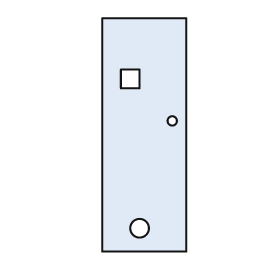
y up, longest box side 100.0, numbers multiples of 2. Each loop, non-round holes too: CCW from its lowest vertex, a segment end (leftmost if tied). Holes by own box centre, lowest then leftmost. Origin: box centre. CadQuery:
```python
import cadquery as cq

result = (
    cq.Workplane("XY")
    .moveTo(-18.0, -50.0)
    .lineTo(18.0, -50.0)
    .lineTo(18.0, 50.0)
    .lineTo(-18.0, 50.0)
    .close()
    .moveTo(-2.0, -40.0)
    .circle(4.0)
    .moveTo(12.0, 6.0)
    .circle(2.0)
    .moveTo(-10.0, 20.0)
    .lineTo(-2.0, 20.0)
    .lineTo(-2.0, 28.0)
    .lineTo(-10.0, 28.0)
    .close()
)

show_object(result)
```